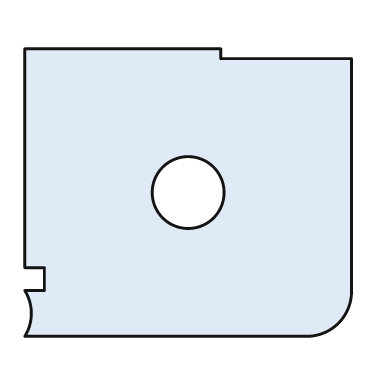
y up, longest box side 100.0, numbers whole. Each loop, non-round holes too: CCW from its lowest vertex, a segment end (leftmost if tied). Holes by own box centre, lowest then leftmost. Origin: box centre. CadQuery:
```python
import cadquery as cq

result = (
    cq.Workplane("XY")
    .moveTo(-50.0, -44.0)
    .lineTo(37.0, -44.0)
    .threePointArc((46.0, -40.0), (50.0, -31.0))
    .lineTo(50.0, 41.0)
    .lineTo(10.0, 41.0)
    .lineTo(10.0, 44.0)
    .lineTo(-50.0, 44.0)
    .lineTo(-50.0, -23.0)
    .lineTo(-44.0, -23.0)
    .lineTo(-44.0, -30.0)
    .lineTo(-50.0, -30.0)
    .threePointArc((-48.0, -37.0), (-50.0, -44.0))
    .close()
    .moveTo(0.0, 0.0)
    .circle(11.0)
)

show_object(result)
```